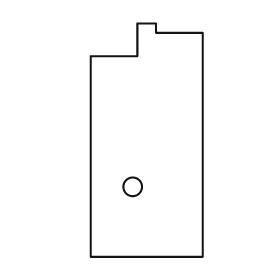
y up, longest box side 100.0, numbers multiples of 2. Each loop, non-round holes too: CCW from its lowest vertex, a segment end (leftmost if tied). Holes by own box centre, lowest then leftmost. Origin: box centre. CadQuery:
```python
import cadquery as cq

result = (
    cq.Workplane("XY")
    .moveTo(-24.0, -50.0)
    .lineTo(24.0, -50.0)
    .lineTo(24.0, 46.0)
    .lineTo(4.0, 46.0)
    .lineTo(4.0, 50.0)
    .lineTo(-4.0, 50.0)
    .lineTo(-4.0, 36.0)
    .lineTo(-24.0, 36.0)
    .close()
    .moveTo(-6.0, -20.0)
    .circle(4.0)
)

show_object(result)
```